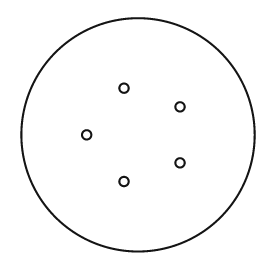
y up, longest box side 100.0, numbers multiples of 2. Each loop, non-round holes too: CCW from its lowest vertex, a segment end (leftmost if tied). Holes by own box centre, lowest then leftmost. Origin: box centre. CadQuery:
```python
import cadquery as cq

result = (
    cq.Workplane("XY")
    .moveTo(0.0, 0.0)
    .circle(50.0)
    .moveTo(-6.0, -20.0)
    .circle(2.0)
    .moveTo(18.0, -12.0)
    .circle(2.0)
    .moveTo(-22.0, 0.0)
    .circle(2.0)
    .moveTo(18.0, 12.0)
    .circle(2.0)
    .moveTo(-6.0, 20.0)
    .circle(2.0)
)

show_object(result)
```